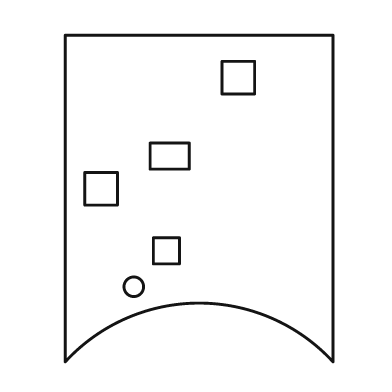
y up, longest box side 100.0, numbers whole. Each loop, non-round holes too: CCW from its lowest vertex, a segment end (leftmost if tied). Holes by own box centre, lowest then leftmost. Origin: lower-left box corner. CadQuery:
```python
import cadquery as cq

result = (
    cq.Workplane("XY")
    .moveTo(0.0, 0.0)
    .threePointArc((41.0, 18.0), (82.0, 0.0))
    .lineTo(82.0, 100.0)
    .lineTo(0.0, 100.0)
    .close()
    .moveTo(21.0, 23.0)
    .circle(3.0)
    .moveTo(27.0, 30.0)
    .lineTo(35.0, 30.0)
    .lineTo(35.0, 38.0)
    .lineTo(27.0, 38.0)
    .close()
    .moveTo(6.0, 48.0)
    .lineTo(16.0, 48.0)
    .lineTo(16.0, 58.0)
    .lineTo(6.0, 58.0)
    .close()
    .moveTo(26.0, 59.0)
    .lineTo(38.0, 59.0)
    .lineTo(38.0, 67.0)
    .lineTo(26.0, 67.0)
    .close()
    .moveTo(48.0, 82.0)
    .lineTo(58.0, 82.0)
    .lineTo(58.0, 92.0)
    .lineTo(48.0, 92.0)
    .close()
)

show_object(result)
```